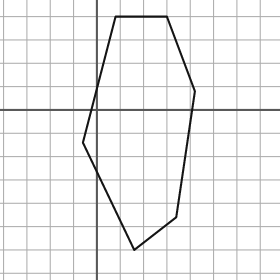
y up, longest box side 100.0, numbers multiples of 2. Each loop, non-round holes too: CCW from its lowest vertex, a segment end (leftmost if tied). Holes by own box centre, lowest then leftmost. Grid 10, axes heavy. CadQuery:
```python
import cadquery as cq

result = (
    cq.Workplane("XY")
    .moveTo(16.0, -60.0)
    .lineTo(34.0, -46.0)
    .lineTo(42.0, 8.0)
    .lineTo(30.0, 40.0)
    .lineTo(8.0, 40.0)
    .lineTo(-6.0, -14.0)
    .close()
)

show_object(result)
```